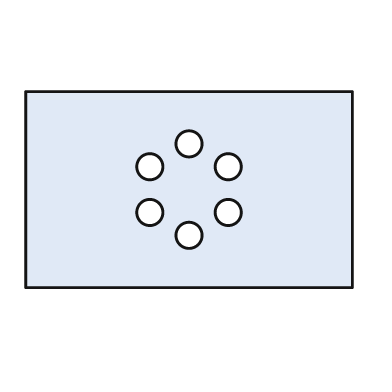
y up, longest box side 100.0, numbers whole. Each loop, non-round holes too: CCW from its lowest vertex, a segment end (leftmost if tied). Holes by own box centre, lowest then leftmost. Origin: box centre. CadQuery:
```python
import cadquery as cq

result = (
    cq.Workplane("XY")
    .moveTo(-50.0, -30.0)
    .lineTo(50.0, -30.0)
    .lineTo(50.0, 30.0)
    .lineTo(-50.0, 30.0)
    .close()
    .moveTo(0.0, -14.0)
    .circle(4.0)
    .moveTo(-12.0, -7.0)
    .circle(4.0)
    .moveTo(12.0, -7.0)
    .circle(4.0)
    .moveTo(-12.0, 7.0)
    .circle(4.0)
    .moveTo(12.0, 7.0)
    .circle(4.0)
    .moveTo(0.0, 14.0)
    .circle(4.0)
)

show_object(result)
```